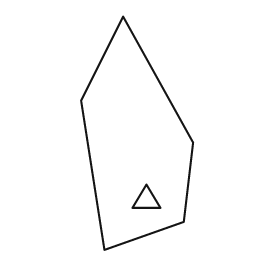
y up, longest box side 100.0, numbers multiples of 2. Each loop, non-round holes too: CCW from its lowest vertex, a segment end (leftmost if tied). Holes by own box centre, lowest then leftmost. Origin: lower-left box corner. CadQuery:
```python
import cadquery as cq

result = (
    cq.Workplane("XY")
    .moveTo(10.0, 0.0)
    .lineTo(44.0, 12.0)
    .lineTo(48.0, 46.0)
    .lineTo(18.0, 100.0)
    .lineTo(0.0, 64.0)
    .close()
    .moveTo(22.0, 18.0)
    .lineTo(34.0, 18.0)
    .lineTo(28.0, 28.0)
    .close()
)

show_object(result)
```